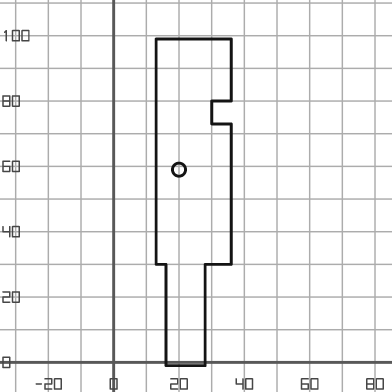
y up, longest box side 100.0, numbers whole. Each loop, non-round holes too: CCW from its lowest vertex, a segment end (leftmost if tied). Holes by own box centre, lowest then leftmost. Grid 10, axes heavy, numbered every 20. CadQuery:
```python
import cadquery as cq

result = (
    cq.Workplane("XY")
    .moveTo(16.0, -1.0)
    .lineTo(28.0, -1.0)
    .lineTo(28.0, 30.0)
    .lineTo(36.0, 30.0)
    .lineTo(36.0, 73.0)
    .lineTo(30.0, 73.0)
    .lineTo(30.0, 80.0)
    .lineTo(36.0, 80.0)
    .lineTo(36.0, 99.0)
    .lineTo(13.0, 99.0)
    .lineTo(13.0, 30.0)
    .lineTo(16.0, 30.0)
    .close()
    .moveTo(20.0, 59.0)
    .circle(2.0)
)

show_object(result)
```